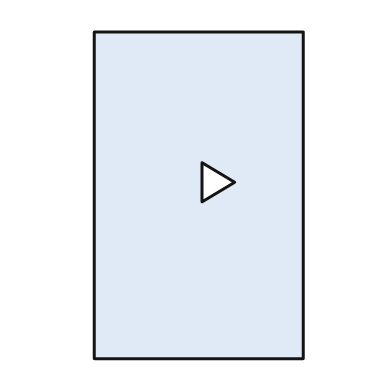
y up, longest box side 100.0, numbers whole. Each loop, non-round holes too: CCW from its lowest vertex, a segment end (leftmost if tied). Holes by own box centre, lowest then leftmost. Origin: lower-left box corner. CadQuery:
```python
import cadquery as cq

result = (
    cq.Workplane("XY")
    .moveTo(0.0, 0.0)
    .lineTo(64.0, 0.0)
    .lineTo(64.0, 100.0)
    .lineTo(0.0, 100.0)
    .close()
    .moveTo(33.0, 48.0)
    .lineTo(43.0, 54.0)
    .lineTo(33.0, 60.0)
    .close()
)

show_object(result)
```